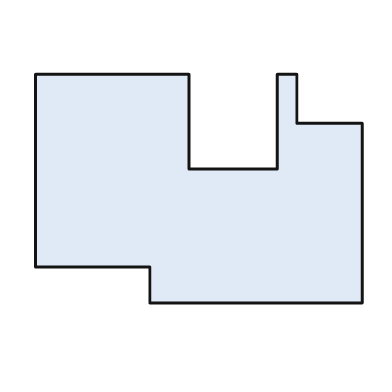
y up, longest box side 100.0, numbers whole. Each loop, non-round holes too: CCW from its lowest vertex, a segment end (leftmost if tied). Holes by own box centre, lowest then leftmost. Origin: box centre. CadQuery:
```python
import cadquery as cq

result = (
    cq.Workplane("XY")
    .moveTo(-15.0, -35.0)
    .lineTo(50.0, -35.0)
    .lineTo(50.0, 20.0)
    .lineTo(30.0, 20.0)
    .lineTo(30.0, 35.0)
    .lineTo(24.0, 35.0)
    .lineTo(24.0, 6.0)
    .lineTo(-3.0, 6.0)
    .lineTo(-3.0, 35.0)
    .lineTo(-50.0, 35.0)
    .lineTo(-50.0, -24.0)
    .lineTo(-15.0, -24.0)
    .close()
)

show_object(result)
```